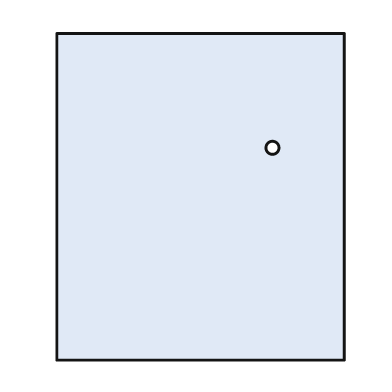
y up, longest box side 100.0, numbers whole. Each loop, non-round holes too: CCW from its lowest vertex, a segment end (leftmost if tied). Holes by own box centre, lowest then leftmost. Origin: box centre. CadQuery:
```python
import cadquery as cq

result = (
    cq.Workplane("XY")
    .moveTo(-44.0, -50.0)
    .lineTo(44.0, -50.0)
    .lineTo(44.0, 50.0)
    .lineTo(-44.0, 50.0)
    .close()
    .moveTo(22.0, 15.0)
    .circle(2.0)
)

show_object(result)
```